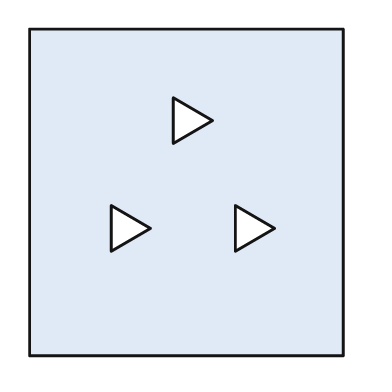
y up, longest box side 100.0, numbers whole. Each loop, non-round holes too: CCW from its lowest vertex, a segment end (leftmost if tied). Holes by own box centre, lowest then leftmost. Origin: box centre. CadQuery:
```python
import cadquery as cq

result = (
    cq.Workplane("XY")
    .moveTo(-48.0, -50.0)
    .lineTo(48.0, -50.0)
    .lineTo(48.0, 50.0)
    .lineTo(-48.0, 50.0)
    .close()
    .moveTo(-23.0, -18.0)
    .lineTo(-11.0, -11.0)
    .lineTo(-23.0, -4.0)
    .close()
    .moveTo(15.0, -18.0)
    .lineTo(27.0, -11.0)
    .lineTo(15.0, -4.0)
    .close()
    .moveTo(-4.0, 15.0)
    .lineTo(8.0, 22.0)
    .lineTo(-4.0, 29.0)
    .close()
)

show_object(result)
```